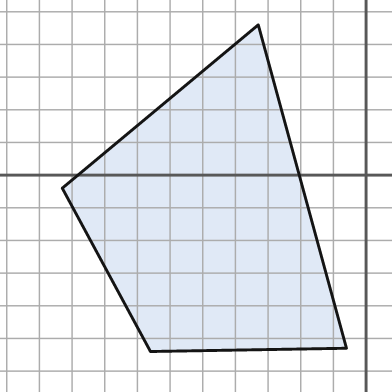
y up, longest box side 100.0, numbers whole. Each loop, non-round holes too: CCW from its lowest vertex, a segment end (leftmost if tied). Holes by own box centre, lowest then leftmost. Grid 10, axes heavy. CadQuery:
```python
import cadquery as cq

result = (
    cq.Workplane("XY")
    .moveTo(-66.0, -54.0)
    .lineTo(-6.0, -53.0)
    .lineTo(-33.0, 46.0)
    .lineTo(-93.0, -4.0)
    .close()
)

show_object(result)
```